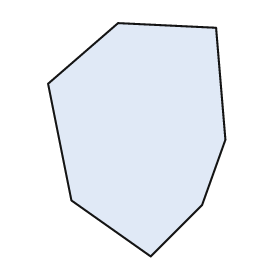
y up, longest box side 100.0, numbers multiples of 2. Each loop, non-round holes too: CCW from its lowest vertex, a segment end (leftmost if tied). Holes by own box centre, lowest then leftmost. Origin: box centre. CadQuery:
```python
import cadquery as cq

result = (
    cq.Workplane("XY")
    .moveTo(6.0, -50.0)
    .lineTo(28.0, -28.0)
    .lineTo(38.0, 0.0)
    .lineTo(34.0, 48.0)
    .lineTo(-8.0, 50.0)
    .lineTo(-38.0, 24.0)
    .lineTo(-28.0, -26.0)
    .close()
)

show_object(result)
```